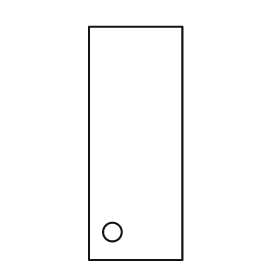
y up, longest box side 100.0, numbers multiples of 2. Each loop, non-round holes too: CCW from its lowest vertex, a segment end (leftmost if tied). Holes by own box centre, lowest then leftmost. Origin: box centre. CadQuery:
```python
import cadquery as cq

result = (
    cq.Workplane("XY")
    .moveTo(-20.0, -50.0)
    .lineTo(20.0, -50.0)
    .lineTo(20.0, 50.0)
    .lineTo(-20.0, 50.0)
    .close()
    .moveTo(-10.0, -38.0)
    .circle(4.0)
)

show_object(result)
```